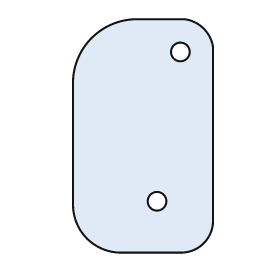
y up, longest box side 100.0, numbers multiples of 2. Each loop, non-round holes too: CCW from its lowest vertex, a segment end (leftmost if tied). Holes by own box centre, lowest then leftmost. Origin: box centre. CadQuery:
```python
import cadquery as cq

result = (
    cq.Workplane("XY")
    .moveTo(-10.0, -50.0)
    .lineTo(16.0, -50.0)
    .threePointArc((26.0, -46.0), (30.0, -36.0))
    .lineTo(30.0, 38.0)
    .threePointArc((26.0, 46.0), (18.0, 50.0))
    .lineTo(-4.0, 50.0)
    .threePointArc((-22.0, 42.0), (-30.0, 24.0))
    .lineTo(-30.0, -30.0)
    .threePointArc((-24.0, -44.0), (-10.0, -50.0))
    .close()
    .moveTo(6.0, -28.0)
    .circle(4.0)
    .moveTo(16.0, 36.0)
    .circle(4.0)
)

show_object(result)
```